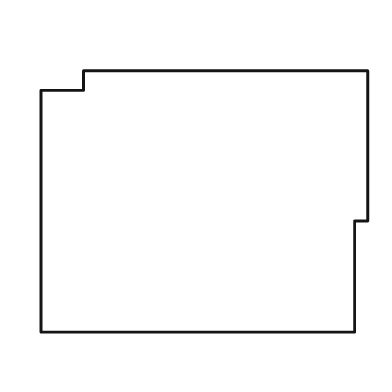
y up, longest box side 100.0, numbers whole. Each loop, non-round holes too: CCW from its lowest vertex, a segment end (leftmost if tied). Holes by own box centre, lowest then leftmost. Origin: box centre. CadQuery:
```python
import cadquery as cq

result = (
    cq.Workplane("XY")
    .moveTo(-50.0, -40.0)
    .lineTo(46.0, -40.0)
    .lineTo(46.0, -6.0)
    .lineTo(50.0, -6.0)
    .lineTo(50.0, 40.0)
    .lineTo(-37.0, 40.0)
    .lineTo(-37.0, 34.0)
    .lineTo(-50.0, 34.0)
    .close()
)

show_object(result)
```